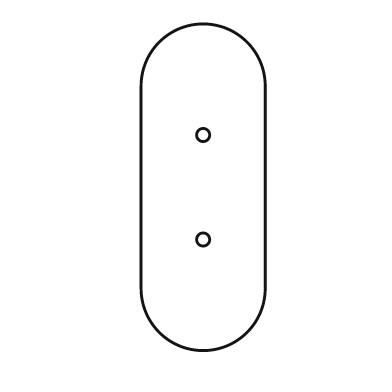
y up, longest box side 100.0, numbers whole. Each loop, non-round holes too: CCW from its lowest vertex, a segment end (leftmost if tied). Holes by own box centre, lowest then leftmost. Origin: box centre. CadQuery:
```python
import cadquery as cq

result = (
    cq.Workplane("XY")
    .moveTo(-19.0, -31.0)
    .threePointArc((0.0, -50.0), (19.0, -31.0))
    .lineTo(19.0, 31.0)
    .threePointArc((0.0, 50.0), (-19.0, 31.0))
    .close()
    .moveTo(0.0, -16.0)
    .circle(2.0)
    .moveTo(0.0, 16.0)
    .circle(2.0)
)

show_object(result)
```